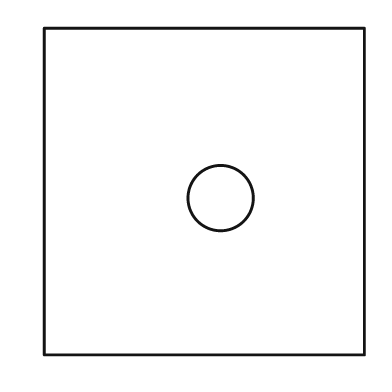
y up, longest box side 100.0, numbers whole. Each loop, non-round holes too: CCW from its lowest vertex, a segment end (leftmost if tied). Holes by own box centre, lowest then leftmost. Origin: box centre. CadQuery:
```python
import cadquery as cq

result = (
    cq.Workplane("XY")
    .moveTo(-49.0, -50.0)
    .lineTo(49.0, -50.0)
    .lineTo(49.0, 50.0)
    .lineTo(-49.0, 50.0)
    .close()
    .moveTo(5.0, -2.0)
    .circle(10.0)
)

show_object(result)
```